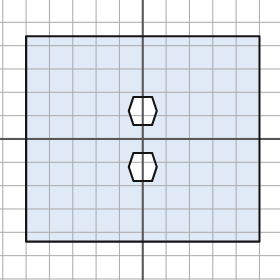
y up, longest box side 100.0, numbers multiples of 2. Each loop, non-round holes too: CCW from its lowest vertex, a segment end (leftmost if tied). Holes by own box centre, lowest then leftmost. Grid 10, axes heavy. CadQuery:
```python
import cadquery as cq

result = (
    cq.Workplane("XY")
    .moveTo(-50.0, -44.0)
    .lineTo(50.0, -44.0)
    .lineTo(50.0, 44.0)
    .lineTo(-50.0, 44.0)
    .close()
    .moveTo(-4.0, -18.0)
    .lineTo(4.0, -18.0)
    .lineTo(6.0, -12.0)
    .lineTo(4.0, -6.0)
    .lineTo(-4.0, -6.0)
    .lineTo(-6.0, -12.0)
    .close()
    .moveTo(-4.0, 6.0)
    .lineTo(4.0, 6.0)
    .lineTo(6.0, 12.0)
    .lineTo(4.0, 18.0)
    .lineTo(-4.0, 18.0)
    .lineTo(-6.0, 12.0)
    .close()
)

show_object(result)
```